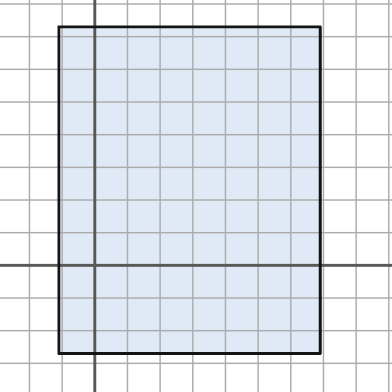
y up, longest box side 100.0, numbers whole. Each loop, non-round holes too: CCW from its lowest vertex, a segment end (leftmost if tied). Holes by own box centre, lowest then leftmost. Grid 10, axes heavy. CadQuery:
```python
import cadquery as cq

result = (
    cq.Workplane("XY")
    .moveTo(-11.0, -27.0)
    .lineTo(69.0, -27.0)
    .lineTo(69.0, 73.0)
    .lineTo(-11.0, 73.0)
    .close()
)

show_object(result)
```